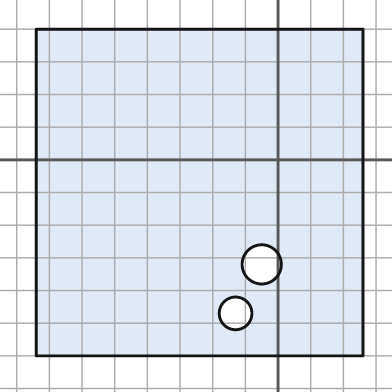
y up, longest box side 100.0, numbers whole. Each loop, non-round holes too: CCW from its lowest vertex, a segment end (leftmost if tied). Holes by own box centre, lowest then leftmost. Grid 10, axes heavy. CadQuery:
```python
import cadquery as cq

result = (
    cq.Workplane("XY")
    .moveTo(-74.0, -60.0)
    .lineTo(26.0, -60.0)
    .lineTo(26.0, 40.0)
    .lineTo(-74.0, 40.0)
    .close()
    .moveTo(-13.0, -47.0)
    .circle(5.0)
    .moveTo(-5.0, -32.0)
    .circle(6.0)
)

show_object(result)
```